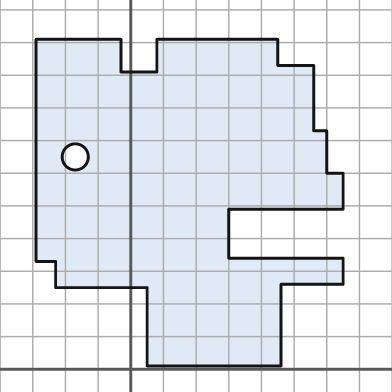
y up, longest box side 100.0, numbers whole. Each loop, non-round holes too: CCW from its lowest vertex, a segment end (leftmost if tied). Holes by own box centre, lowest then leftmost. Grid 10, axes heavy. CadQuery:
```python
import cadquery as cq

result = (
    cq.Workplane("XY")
    .moveTo(5.0, 1.0)
    .lineTo(46.0, 1.0)
    .lineTo(46.0, 26.0)
    .lineTo(65.0, 26.0)
    .lineTo(65.0, 34.0)
    .lineTo(30.0, 34.0)
    .lineTo(30.0, 49.0)
    .lineTo(65.0, 49.0)
    .lineTo(65.0, 60.0)
    .lineTo(60.0, 60.0)
    .lineTo(60.0, 73.0)
    .lineTo(56.0, 73.0)
    .lineTo(56.0, 93.0)
    .lineTo(45.0, 93.0)
    .lineTo(45.0, 101.0)
    .lineTo(8.0, 101.0)
    .lineTo(8.0, 91.0)
    .lineTo(-3.0, 91.0)
    .lineTo(-3.0, 101.0)
    .lineTo(-29.0, 101.0)
    .lineTo(-29.0, 33.0)
    .lineTo(-23.0, 33.0)
    .lineTo(-23.0, 25.0)
    .lineTo(5.0, 25.0)
    .close()
    .moveTo(-17.0, 65.0)
    .circle(4.0)
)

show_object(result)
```